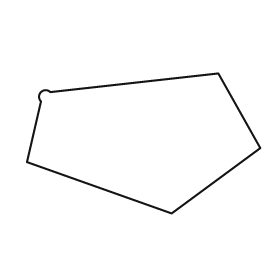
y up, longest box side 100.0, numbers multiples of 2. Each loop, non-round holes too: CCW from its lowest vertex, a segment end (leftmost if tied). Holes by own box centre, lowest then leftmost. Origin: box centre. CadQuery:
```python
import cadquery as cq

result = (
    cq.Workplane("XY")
    .moveTo(12.0, -30.0)
    .lineTo(50.0, -2.0)
    .lineTo(32.0, 30.0)
    .lineTo(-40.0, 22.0)
    .threePointArc((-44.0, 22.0), (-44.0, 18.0))
    .lineTo(-50.0, -8.0)
    .close()
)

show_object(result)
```